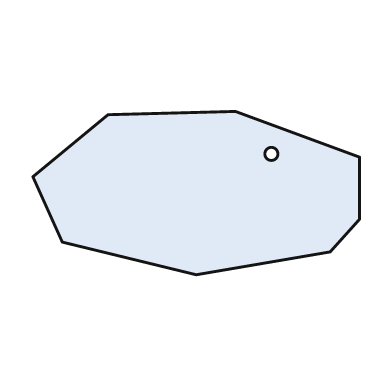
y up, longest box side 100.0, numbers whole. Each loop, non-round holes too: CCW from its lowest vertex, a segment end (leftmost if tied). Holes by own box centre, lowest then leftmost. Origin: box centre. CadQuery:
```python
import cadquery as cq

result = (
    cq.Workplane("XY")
    .moveTo(0.0, -25.0)
    .lineTo(41.0, -18.0)
    .lineTo(50.0, -8.0)
    .lineTo(50.0, 11.0)
    .lineTo(12.0, 25.0)
    .lineTo(-27.0, 24.0)
    .lineTo(-50.0, 5.0)
    .lineTo(-41.0, -15.0)
    .close()
    .moveTo(23.0, 12.0)
    .circle(2.0)
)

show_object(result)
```